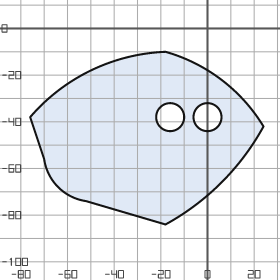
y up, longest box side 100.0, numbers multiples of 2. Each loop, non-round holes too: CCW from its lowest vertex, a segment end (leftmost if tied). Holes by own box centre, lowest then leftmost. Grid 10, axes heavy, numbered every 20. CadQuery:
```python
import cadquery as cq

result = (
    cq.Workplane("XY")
    .moveTo(-18.0, -84.0)
    .threePointArc((6.0, -66.0), (24.0, -42.0))
    .threePointArc((6.0, -22.0), (-18.0, -10.0))
    .threePointArc((-50.0, -18.0), (-76.0, -38.0))
    .lineTo(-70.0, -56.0)
    .threePointArc((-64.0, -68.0), (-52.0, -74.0))
    .close()
    .moveTo(-16.0, -38.0)
    .circle(6.0)
    .moveTo(0.0, -38.0)
    .circle(6.0)
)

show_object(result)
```